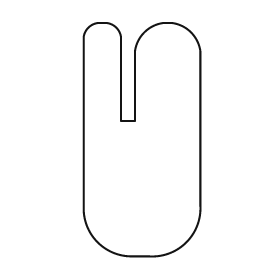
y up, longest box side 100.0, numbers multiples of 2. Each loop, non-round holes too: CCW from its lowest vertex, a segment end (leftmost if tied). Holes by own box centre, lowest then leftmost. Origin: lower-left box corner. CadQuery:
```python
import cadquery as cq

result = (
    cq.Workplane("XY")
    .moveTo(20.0, 0.0)
    .lineTo(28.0, 0.0)
    .threePointArc((44.0, 6.0), (50.0, 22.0))
    .lineTo(50.0, 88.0)
    .threePointArc((46.0, 96.0), (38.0, 100.0))
    .lineTo(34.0, 100.0)
    .threePointArc((26.0, 96.0), (22.0, 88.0))
    .lineTo(22.0, 58.0)
    .lineTo(16.0, 58.0)
    .lineTo(16.0, 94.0)
    .threePointArc((14.0, 98.0), (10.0, 100.0))
    .lineTo(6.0, 100.0)
    .threePointArc((2.0, 98.0), (0.0, 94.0))
    .lineTo(0.0, 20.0)
    .threePointArc((6.0, 6.0), (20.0, 0.0))
    .close()
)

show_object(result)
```